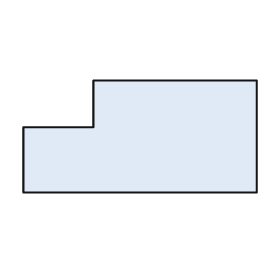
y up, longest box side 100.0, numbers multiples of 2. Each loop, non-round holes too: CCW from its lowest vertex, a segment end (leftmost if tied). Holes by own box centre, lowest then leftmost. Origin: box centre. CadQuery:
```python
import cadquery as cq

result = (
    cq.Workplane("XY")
    .moveTo(-50.0, -24.0)
    .lineTo(50.0, -24.0)
    .lineTo(50.0, 24.0)
    .lineTo(-20.0, 24.0)
    .lineTo(-20.0, 4.0)
    .lineTo(-50.0, 4.0)
    .close()
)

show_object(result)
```